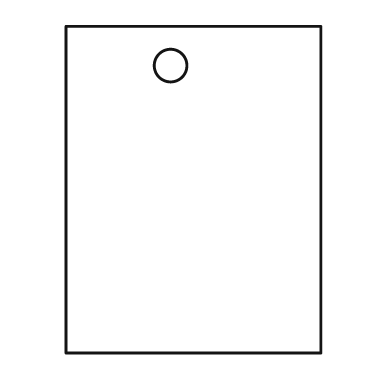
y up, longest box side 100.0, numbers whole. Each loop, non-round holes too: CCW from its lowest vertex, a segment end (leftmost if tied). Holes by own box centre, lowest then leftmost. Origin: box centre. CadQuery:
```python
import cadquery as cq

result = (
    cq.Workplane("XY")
    .moveTo(-39.0, -50.0)
    .lineTo(39.0, -50.0)
    .lineTo(39.0, 50.0)
    .lineTo(-39.0, 50.0)
    .close()
    .moveTo(-7.0, 38.0)
    .circle(5.0)
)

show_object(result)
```